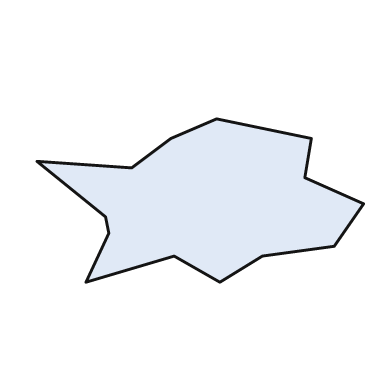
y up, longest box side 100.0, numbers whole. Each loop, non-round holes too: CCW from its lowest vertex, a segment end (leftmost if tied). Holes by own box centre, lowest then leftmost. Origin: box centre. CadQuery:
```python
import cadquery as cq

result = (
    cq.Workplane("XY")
    .moveTo(-35.0, -25.0)
    .lineTo(-8.0, -17.0)
    .lineTo(6.0, -25.0)
    .lineTo(19.0, -17.0)
    .lineTo(41.0, -14.0)
    .lineTo(50.0, -1.0)
    .lineTo(32.0, 7.0)
    .lineTo(34.0, 19.0)
    .lineTo(5.0, 25.0)
    .lineTo(-9.0, 19.0)
    .lineTo(-21.0, 10.0)
    .lineTo(-50.0, 12.0)
    .lineTo(-29.0, -5.0)
    .lineTo(-28.0, -10.0)
    .close()
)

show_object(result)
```